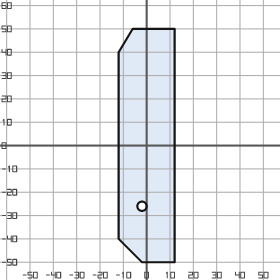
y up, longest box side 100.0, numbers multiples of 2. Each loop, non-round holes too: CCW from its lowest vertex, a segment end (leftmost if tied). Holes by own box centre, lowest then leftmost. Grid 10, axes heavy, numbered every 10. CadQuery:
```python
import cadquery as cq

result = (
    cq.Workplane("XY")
    .moveTo(-2.0, -50.0)
    .lineTo(12.0, -50.0)
    .lineTo(12.0, 50.0)
    .lineTo(-6.0, 50.0)
    .lineTo(-12.0, 40.0)
    .lineTo(-12.0, -40.0)
    .close()
    .moveTo(-2.0, -26.0)
    .circle(2.0)
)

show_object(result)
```